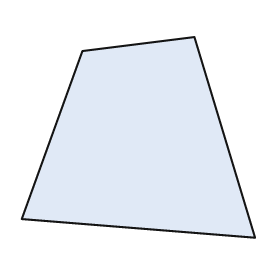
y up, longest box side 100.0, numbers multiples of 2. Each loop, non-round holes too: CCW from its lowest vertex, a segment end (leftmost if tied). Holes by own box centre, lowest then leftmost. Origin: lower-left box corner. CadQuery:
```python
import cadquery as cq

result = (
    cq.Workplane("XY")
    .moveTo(100.0, 0.0)
    .lineTo(74.0, 86.0)
    .lineTo(26.0, 80.0)
    .lineTo(0.0, 8.0)
    .close()
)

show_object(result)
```